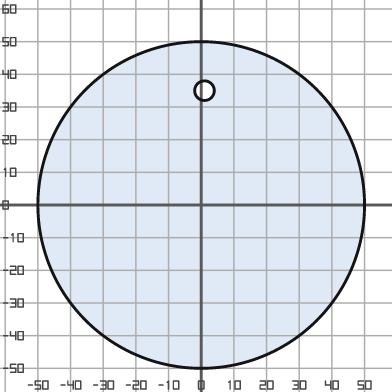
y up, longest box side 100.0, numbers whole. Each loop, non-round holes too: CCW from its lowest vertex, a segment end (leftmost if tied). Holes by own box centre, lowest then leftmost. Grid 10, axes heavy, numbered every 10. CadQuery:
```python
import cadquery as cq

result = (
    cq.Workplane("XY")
    .moveTo(0.0, 0.0)
    .circle(50.0)
    .moveTo(1.0, 35.0)
    .circle(3.0)
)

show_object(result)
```